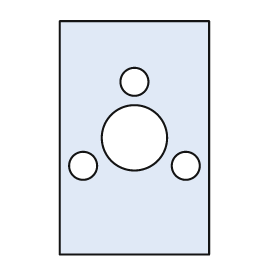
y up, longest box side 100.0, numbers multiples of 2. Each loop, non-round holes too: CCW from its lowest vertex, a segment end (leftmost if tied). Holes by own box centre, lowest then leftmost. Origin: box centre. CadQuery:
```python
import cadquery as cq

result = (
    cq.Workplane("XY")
    .moveTo(-32.0, -50.0)
    .lineTo(32.0, -50.0)
    .lineTo(32.0, 50.0)
    .lineTo(-32.0, 50.0)
    .close()
    .moveTo(-22.0, -12.0)
    .circle(6.0)
    .moveTo(22.0, -12.0)
    .circle(6.0)
    .moveTo(0.0, 0.0)
    .circle(14.0)
    .moveTo(0.0, 24.0)
    .circle(6.0)
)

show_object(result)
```